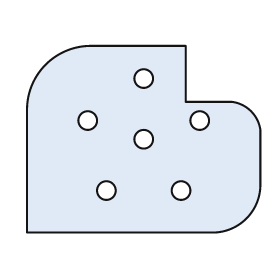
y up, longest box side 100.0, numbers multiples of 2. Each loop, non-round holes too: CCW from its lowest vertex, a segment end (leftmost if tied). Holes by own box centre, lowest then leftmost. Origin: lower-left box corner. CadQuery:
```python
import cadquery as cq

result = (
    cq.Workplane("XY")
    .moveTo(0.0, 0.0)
    .lineTo(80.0, 0.0)
    .threePointArc((94.0, 6.0), (100.0, 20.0))
    .lineTo(100.0, 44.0)
    .threePointArc((96.0, 52.0), (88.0, 56.0))
    .lineTo(68.0, 56.0)
    .lineTo(68.0, 80.0)
    .lineTo(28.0, 80.0)
    .threePointArc((8.0, 72.0), (0.0, 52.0))
    .close()
    .moveTo(34.0, 18.0)
    .circle(4.0)
    .moveTo(66.0, 18.0)
    .circle(4.0)
    .moveTo(50.0, 40.0)
    .circle(4.0)
    .moveTo(26.0, 48.0)
    .circle(4.0)
    .moveTo(74.0, 48.0)
    .circle(4.0)
    .moveTo(50.0, 66.0)
    .circle(4.0)
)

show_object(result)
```